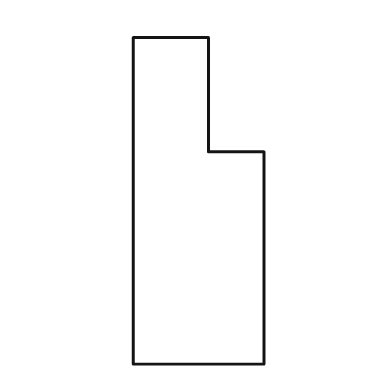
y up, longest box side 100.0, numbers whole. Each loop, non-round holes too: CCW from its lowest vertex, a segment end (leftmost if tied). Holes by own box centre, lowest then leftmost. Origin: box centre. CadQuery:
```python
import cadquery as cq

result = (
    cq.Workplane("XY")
    .moveTo(-20.0, -50.0)
    .lineTo(20.0, -50.0)
    .lineTo(20.0, 15.0)
    .lineTo(3.0, 15.0)
    .lineTo(3.0, 50.0)
    .lineTo(-20.0, 50.0)
    .close()
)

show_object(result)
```